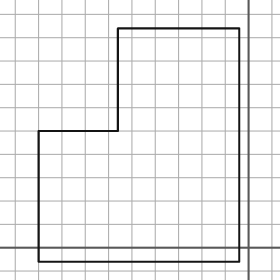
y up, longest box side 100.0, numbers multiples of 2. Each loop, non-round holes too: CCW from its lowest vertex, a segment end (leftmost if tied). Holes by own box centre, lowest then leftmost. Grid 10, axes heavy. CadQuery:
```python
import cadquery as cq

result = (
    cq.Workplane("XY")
    .moveTo(-90.0, -6.0)
    .lineTo(-4.0, -6.0)
    .lineTo(-4.0, 94.0)
    .lineTo(-56.0, 94.0)
    .lineTo(-56.0, 50.0)
    .lineTo(-90.0, 50.0)
    .close()
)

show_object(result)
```